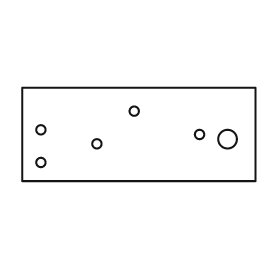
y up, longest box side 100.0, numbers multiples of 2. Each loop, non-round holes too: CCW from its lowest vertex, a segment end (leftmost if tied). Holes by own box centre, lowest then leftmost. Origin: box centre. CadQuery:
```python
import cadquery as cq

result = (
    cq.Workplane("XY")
    .moveTo(-50.0, -20.0)
    .lineTo(50.0, -20.0)
    .lineTo(50.0, 20.0)
    .lineTo(-50.0, 20.0)
    .close()
    .moveTo(-42.0, -12.0)
    .circle(2.0)
    .moveTo(-18.0, -4.0)
    .circle(2.0)
    .moveTo(38.0, -2.0)
    .circle(4.0)
    .moveTo(26.0, 0.0)
    .circle(2.0)
    .moveTo(-42.0, 2.0)
    .circle(2.0)
    .moveTo(-2.0, 10.0)
    .circle(2.0)
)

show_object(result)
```